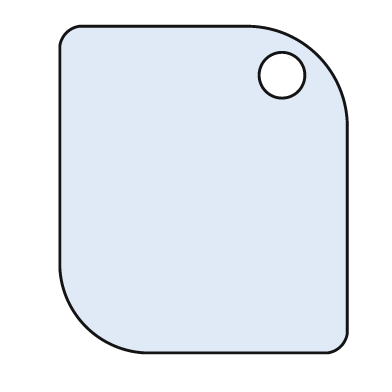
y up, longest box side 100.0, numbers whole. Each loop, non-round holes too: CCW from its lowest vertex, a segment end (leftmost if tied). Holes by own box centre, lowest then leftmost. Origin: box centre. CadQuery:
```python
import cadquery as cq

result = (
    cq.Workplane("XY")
    .moveTo(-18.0, -50.0)
    .lineTo(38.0, -50.0)
    .threePointArc((42.0, -48.0), (44.0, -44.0))
    .lineTo(44.0, 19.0)
    .threePointArc((35.0, 41.0), (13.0, 50.0))
    .lineTo(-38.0, 50.0)
    .threePointArc((-42.0, 48.0), (-44.0, 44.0))
    .lineTo(-44.0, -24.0)
    .threePointArc((-36.0, -42.0), (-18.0, -50.0))
    .close()
    .moveTo(24.0, 35.0)
    .circle(7.0)
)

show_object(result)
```